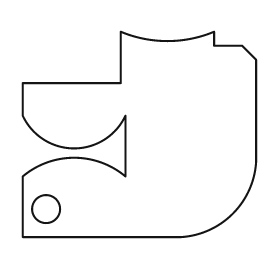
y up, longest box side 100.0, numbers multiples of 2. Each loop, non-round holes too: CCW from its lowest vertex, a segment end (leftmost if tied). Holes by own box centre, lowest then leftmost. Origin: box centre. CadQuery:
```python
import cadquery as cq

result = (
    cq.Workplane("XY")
    .moveTo(-50.0, -44.0)
    .lineTo(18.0, -44.0)
    .threePointArc((40.0, -34.0), (50.0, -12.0))
    .lineTo(50.0, 32.0)
    .lineTo(44.0, 38.0)
    .lineTo(32.0, 38.0)
    .lineTo(32.0, 44.0)
    .threePointArc((12.0, 40.0), (-8.0, 44.0))
    .lineTo(-8.0, 22.0)
    .lineTo(-50.0, 22.0)
    .lineTo(-50.0, 8.0)
    .threePointArc((-28.0, -6.0), (-6.0, 8.0))
    .lineTo(-6.0, -18.0)
    .threePointArc((-28.0, -10.0), (-50.0, -18.0))
    .close()
    .moveTo(-40.0, -32.0)
    .circle(6.0)
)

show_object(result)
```